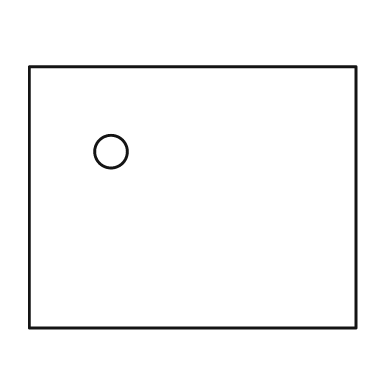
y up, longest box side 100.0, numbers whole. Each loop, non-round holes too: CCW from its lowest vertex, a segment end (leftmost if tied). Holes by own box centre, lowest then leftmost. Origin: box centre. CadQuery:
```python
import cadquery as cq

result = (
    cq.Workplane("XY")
    .moveTo(-50.0, -40.0)
    .lineTo(50.0, -40.0)
    .lineTo(50.0, 40.0)
    .lineTo(-50.0, 40.0)
    .close()
    .moveTo(-25.0, 14.0)
    .circle(5.0)
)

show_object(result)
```